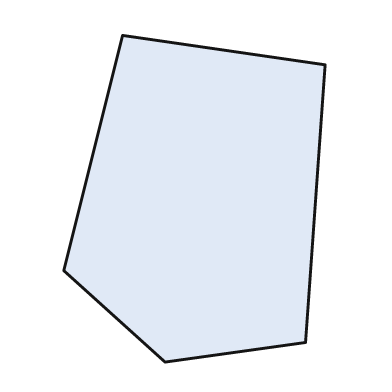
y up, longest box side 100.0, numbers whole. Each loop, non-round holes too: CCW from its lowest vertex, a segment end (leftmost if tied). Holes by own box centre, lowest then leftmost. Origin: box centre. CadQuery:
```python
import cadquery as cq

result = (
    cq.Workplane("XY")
    .moveTo(-9.0, -50.0)
    .lineTo(34.0, -44.0)
    .lineTo(40.0, 41.0)
    .lineTo(-22.0, 50.0)
    .lineTo(-40.0, -22.0)
    .close()
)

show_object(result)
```